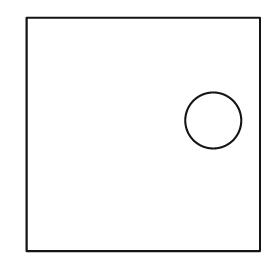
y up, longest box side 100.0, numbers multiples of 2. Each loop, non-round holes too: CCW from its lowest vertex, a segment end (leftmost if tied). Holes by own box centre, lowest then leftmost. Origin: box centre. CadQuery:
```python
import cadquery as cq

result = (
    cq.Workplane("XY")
    .moveTo(-50.0, -50.0)
    .lineTo(50.0, -50.0)
    .lineTo(50.0, 50.0)
    .lineTo(-50.0, 50.0)
    .close()
    .moveTo(30.0, 6.0)
    .circle(12.0)
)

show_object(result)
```